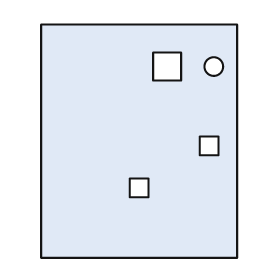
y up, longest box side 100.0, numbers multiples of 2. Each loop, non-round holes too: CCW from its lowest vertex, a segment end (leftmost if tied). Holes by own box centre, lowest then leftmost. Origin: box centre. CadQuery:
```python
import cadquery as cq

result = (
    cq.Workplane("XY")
    .moveTo(-42.0, -50.0)
    .lineTo(42.0, -50.0)
    .lineTo(42.0, 50.0)
    .lineTo(-42.0, 50.0)
    .close()
    .moveTo(-4.0, -24.0)
    .lineTo(4.0, -24.0)
    .lineTo(4.0, -16.0)
    .lineTo(-4.0, -16.0)
    .close()
    .moveTo(26.0, -6.0)
    .lineTo(34.0, -6.0)
    .lineTo(34.0, 2.0)
    .lineTo(26.0, 2.0)
    .close()
    .moveTo(6.0, 26.0)
    .lineTo(18.0, 26.0)
    .lineTo(18.0, 38.0)
    .lineTo(6.0, 38.0)
    .close()
    .moveTo(32.0, 32.0)
    .circle(4.0)
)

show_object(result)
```